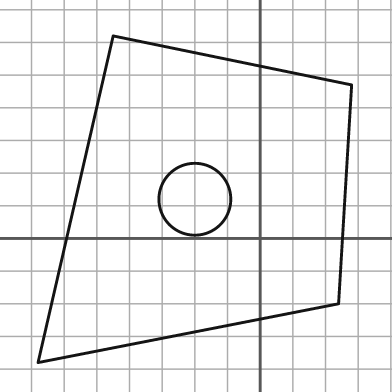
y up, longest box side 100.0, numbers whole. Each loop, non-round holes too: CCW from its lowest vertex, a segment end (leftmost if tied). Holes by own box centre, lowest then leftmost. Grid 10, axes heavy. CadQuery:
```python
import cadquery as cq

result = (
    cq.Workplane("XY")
    .moveTo(-68.0, -38.0)
    .lineTo(24.0, -20.0)
    .lineTo(28.0, 47.0)
    .lineTo(-45.0, 62.0)
    .close()
    .moveTo(-20.0, 12.0)
    .circle(11.0)
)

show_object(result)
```